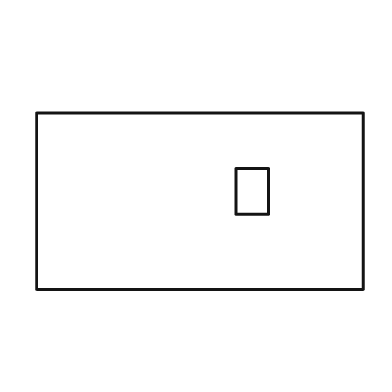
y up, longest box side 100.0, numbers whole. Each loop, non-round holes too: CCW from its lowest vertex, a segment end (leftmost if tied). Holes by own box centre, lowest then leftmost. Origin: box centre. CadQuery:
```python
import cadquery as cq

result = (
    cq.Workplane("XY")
    .moveTo(-50.0, -27.0)
    .lineTo(50.0, -27.0)
    .lineTo(50.0, 27.0)
    .lineTo(-50.0, 27.0)
    .close()
    .moveTo(11.0, -4.0)
    .lineTo(21.0, -4.0)
    .lineTo(21.0, 10.0)
    .lineTo(11.0, 10.0)
    .close()
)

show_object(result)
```